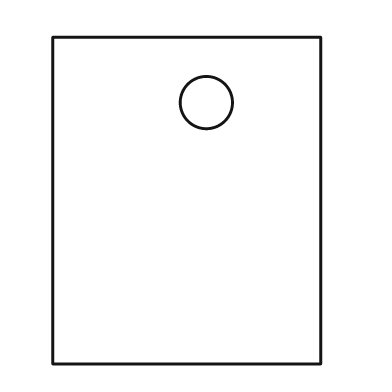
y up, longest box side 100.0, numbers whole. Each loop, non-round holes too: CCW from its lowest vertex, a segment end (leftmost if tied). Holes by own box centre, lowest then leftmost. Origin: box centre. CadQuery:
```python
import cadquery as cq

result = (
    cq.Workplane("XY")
    .moveTo(-41.0, -50.0)
    .lineTo(41.0, -50.0)
    .lineTo(41.0, 50.0)
    .lineTo(-41.0, 50.0)
    .close()
    .moveTo(6.0, 30.0)
    .circle(8.0)
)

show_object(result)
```